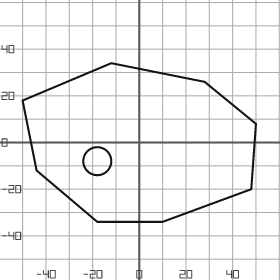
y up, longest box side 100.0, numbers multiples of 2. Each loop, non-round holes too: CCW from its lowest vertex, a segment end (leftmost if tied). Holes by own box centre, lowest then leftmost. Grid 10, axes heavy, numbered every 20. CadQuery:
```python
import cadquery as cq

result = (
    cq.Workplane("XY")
    .moveTo(-18.0, -34.0)
    .lineTo(10.0, -34.0)
    .lineTo(48.0, -20.0)
    .lineTo(50.0, 8.0)
    .lineTo(28.0, 26.0)
    .lineTo(-12.0, 34.0)
    .lineTo(-50.0, 18.0)
    .lineTo(-44.0, -12.0)
    .close()
    .moveTo(-18.0, -8.0)
    .circle(6.0)
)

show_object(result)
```